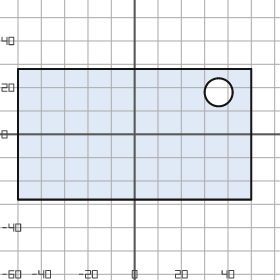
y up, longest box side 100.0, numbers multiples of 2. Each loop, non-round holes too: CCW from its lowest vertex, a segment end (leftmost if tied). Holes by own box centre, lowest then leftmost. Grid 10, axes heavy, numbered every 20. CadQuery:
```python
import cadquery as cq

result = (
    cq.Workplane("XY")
    .moveTo(-50.0, -28.0)
    .lineTo(50.0, -28.0)
    .lineTo(50.0, 28.0)
    .lineTo(-50.0, 28.0)
    .close()
    .moveTo(36.0, 18.0)
    .circle(6.0)
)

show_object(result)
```